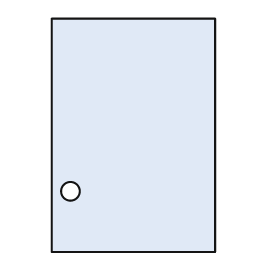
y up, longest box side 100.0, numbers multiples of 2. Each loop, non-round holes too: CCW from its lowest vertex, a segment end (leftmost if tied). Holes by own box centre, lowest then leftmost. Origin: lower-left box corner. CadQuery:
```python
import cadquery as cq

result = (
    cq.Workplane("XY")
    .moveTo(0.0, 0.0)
    .lineTo(70.0, 0.0)
    .lineTo(70.0, 100.0)
    .lineTo(0.0, 100.0)
    .close()
    .moveTo(8.0, 26.0)
    .circle(4.0)
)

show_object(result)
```